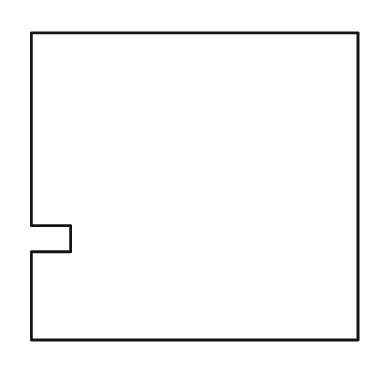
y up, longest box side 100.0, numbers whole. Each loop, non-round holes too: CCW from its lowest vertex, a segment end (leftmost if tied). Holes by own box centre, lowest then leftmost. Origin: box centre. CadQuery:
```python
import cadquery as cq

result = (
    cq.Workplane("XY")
    .moveTo(-50.0, -47.0)
    .lineTo(50.0, -47.0)
    .lineTo(50.0, 47.0)
    .lineTo(-50.0, 47.0)
    .lineTo(-50.0, -12.0)
    .lineTo(-38.0, -12.0)
    .lineTo(-38.0, -20.0)
    .lineTo(-50.0, -20.0)
    .close()
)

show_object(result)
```